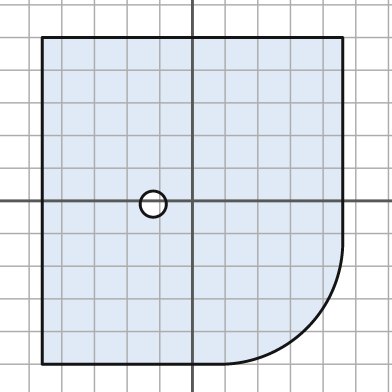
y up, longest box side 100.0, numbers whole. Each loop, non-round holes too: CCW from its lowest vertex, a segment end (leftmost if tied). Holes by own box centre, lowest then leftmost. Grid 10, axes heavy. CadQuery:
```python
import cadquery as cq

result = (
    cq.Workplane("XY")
    .moveTo(-46.0, -50.0)
    .lineTo(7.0, -50.0)
    .threePointArc((35.0, -39.0), (46.0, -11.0))
    .lineTo(46.0, 50.0)
    .lineTo(-46.0, 50.0)
    .close()
    .moveTo(-12.0, -1.0)
    .circle(4.0)
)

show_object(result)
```